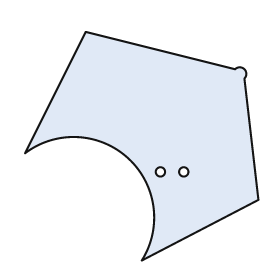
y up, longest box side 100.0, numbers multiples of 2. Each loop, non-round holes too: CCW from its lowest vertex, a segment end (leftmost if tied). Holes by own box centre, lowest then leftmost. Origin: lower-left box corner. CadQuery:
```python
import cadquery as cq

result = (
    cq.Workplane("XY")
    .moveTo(50.0, 0.0)
    .lineTo(100.0, 26.0)
    .lineTo(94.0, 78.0)
    .threePointArc((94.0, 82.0), (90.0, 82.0))
    .lineTo(26.0, 98.0)
    .lineTo(0.0, 46.0)
    .threePointArc((44.0, 44.0), (50.0, 0.0))
    .close()
    .moveTo(58.0, 38.0)
    .circle(2.0)
    .moveTo(68.0, 38.0)
    .circle(2.0)
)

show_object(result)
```